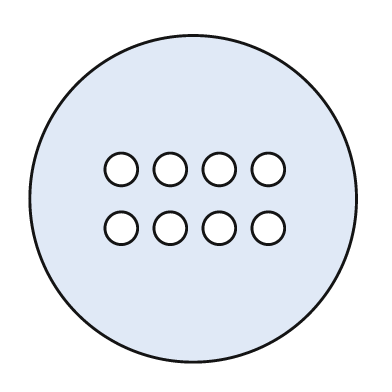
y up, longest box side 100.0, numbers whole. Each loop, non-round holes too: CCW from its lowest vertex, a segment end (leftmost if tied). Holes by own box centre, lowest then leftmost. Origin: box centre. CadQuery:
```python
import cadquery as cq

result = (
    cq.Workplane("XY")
    .moveTo(0.0, 0.0)
    .circle(50.0)
    .moveTo(-22.0, -9.0)
    .circle(5.0)
    .moveTo(-7.0, -9.0)
    .circle(5.0)
    .moveTo(8.0, -9.0)
    .circle(5.0)
    .moveTo(23.0, -9.0)
    .circle(5.0)
    .moveTo(-22.0, 9.0)
    .circle(5.0)
    .moveTo(-7.0, 9.0)
    .circle(5.0)
    .moveTo(8.0, 9.0)
    .circle(5.0)
    .moveTo(23.0, 9.0)
    .circle(5.0)
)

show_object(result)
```